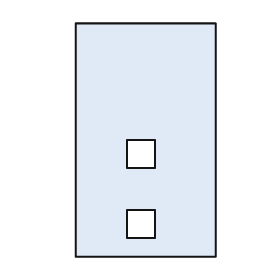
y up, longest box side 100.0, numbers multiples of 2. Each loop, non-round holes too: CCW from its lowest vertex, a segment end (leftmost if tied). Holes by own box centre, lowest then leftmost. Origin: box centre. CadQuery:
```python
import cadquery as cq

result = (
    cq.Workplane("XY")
    .moveTo(-30.0, -50.0)
    .lineTo(30.0, -50.0)
    .lineTo(30.0, 50.0)
    .lineTo(-30.0, 50.0)
    .close()
    .moveTo(-8.0, -42.0)
    .lineTo(4.0, -42.0)
    .lineTo(4.0, -30.0)
    .lineTo(-8.0, -30.0)
    .close()
    .moveTo(-8.0, -12.0)
    .lineTo(4.0, -12.0)
    .lineTo(4.0, 0.0)
    .lineTo(-8.0, 0.0)
    .close()
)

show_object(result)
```